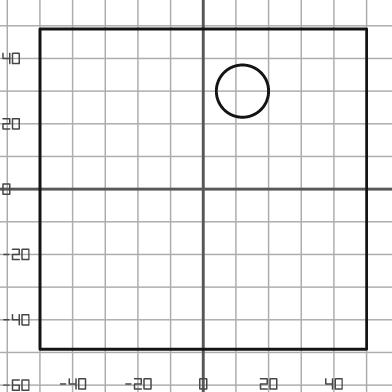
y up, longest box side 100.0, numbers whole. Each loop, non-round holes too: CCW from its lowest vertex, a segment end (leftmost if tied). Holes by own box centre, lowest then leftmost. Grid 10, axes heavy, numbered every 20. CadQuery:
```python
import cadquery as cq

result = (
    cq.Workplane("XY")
    .moveTo(-50.0, -49.0)
    .lineTo(50.0, -49.0)
    .lineTo(50.0, 49.0)
    .lineTo(-50.0, 49.0)
    .close()
    .moveTo(12.0, 30.0)
    .circle(8.0)
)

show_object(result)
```